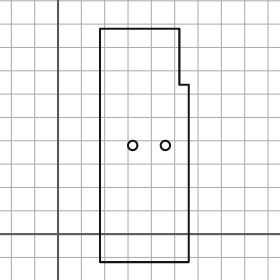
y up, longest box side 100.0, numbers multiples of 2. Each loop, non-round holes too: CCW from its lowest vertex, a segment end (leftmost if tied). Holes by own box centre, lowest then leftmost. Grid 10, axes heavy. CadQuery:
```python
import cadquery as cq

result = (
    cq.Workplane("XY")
    .moveTo(18.0, -12.0)
    .lineTo(56.0, -12.0)
    .lineTo(56.0, 64.0)
    .lineTo(52.0, 64.0)
    .lineTo(52.0, 88.0)
    .lineTo(18.0, 88.0)
    .close()
    .moveTo(32.0, 38.0)
    .circle(2.0)
    .moveTo(46.0, 38.0)
    .circle(2.0)
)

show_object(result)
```